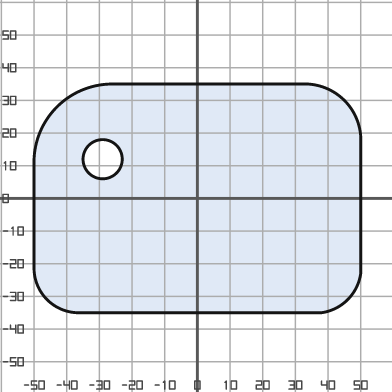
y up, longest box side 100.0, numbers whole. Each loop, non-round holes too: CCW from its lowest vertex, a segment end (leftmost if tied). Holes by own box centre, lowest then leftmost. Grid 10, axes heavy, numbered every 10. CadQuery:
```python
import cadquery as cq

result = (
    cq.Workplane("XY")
    .moveTo(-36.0, -35.0)
    .lineTo(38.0, -35.0)
    .threePointArc((46.0, -31.0), (50.0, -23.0))
    .lineTo(50.0, 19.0)
    .threePointArc((45.0, 30.0), (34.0, 35.0))
    .lineTo(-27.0, 35.0)
    .threePointArc((-43.0, 28.0), (-50.0, 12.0))
    .lineTo(-50.0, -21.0)
    .threePointArc((-46.0, -31.0), (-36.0, -35.0))
    .close()
    .moveTo(-29.0, 12.0)
    .circle(6.0)
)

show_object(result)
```